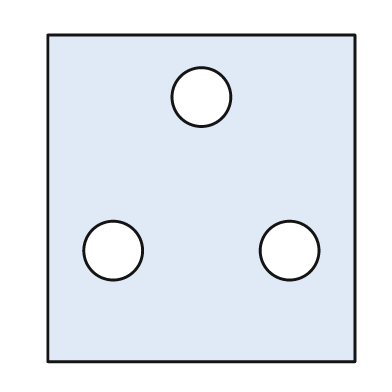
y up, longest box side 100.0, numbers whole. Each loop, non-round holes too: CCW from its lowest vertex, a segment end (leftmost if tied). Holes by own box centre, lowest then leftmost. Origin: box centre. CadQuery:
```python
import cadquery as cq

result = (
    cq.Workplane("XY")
    .moveTo(-47.0, -50.0)
    .lineTo(47.0, -50.0)
    .lineTo(47.0, 50.0)
    .lineTo(-47.0, 50.0)
    .close()
    .moveTo(-27.0, -16.0)
    .circle(9.0)
    .moveTo(27.0, -16.0)
    .circle(9.0)
    .moveTo(0.0, 31.0)
    .circle(9.0)
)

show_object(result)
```